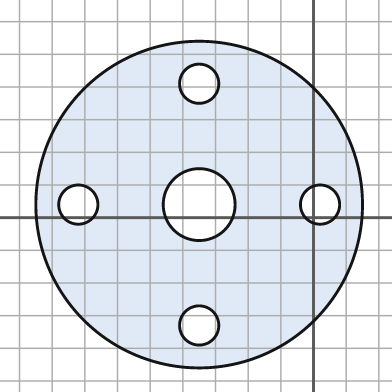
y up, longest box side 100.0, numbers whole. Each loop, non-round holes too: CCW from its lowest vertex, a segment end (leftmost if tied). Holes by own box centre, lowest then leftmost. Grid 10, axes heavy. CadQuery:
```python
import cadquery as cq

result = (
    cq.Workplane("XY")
    .moveTo(-35.0, 4.0)
    .circle(50.0)
    .moveTo(-35.0, -33.0)
    .circle(6.0)
    .moveTo(-72.0, 4.0)
    .circle(6.0)
    .moveTo(-35.0, 4.0)
    .circle(11.0)
    .moveTo(2.0, 4.0)
    .circle(6.0)
    .moveTo(-35.0, 41.0)
    .circle(6.0)
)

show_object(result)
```